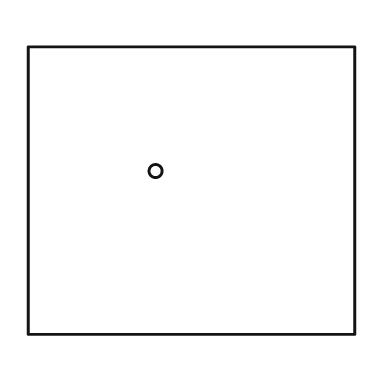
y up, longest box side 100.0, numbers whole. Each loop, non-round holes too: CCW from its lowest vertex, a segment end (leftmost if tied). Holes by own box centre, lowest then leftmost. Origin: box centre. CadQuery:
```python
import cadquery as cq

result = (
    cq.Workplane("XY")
    .moveTo(-50.0, -44.0)
    .lineTo(50.0, -44.0)
    .lineTo(50.0, 44.0)
    .lineTo(-50.0, 44.0)
    .close()
    .moveTo(-11.0, 6.0)
    .circle(2.0)
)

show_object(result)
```